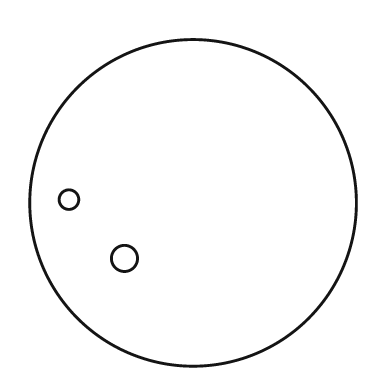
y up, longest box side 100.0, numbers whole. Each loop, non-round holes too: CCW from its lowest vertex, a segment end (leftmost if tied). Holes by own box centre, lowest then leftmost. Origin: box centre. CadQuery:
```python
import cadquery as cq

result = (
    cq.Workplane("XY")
    .moveTo(0.0, 0.0)
    .circle(50.0)
    .moveTo(-21.0, -17.0)
    .circle(4.0)
    .moveTo(-38.0, 1.0)
    .circle(3.0)
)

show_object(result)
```